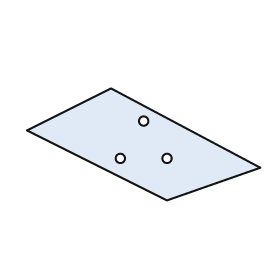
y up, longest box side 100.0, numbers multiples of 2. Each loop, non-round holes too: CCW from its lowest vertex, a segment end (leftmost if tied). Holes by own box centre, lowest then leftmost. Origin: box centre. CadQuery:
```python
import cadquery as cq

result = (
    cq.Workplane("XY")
    .moveTo(10.0, -24.0)
    .lineTo(50.0, -10.0)
    .lineTo(-14.0, 24.0)
    .lineTo(-50.0, 6.0)
    .close()
    .moveTo(-10.0, -6.0)
    .circle(2.0)
    .moveTo(10.0, -6.0)
    .circle(2.0)
    .moveTo(0.0, 10.0)
    .circle(2.0)
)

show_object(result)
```